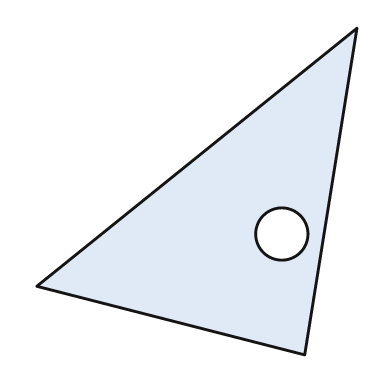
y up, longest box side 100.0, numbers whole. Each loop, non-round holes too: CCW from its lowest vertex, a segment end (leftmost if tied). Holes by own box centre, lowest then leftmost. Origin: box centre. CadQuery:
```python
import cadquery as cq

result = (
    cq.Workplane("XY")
    .moveTo(33.0, -50.0)
    .lineTo(49.0, 50.0)
    .lineTo(-49.0, -29.0)
    .close()
    .moveTo(26.0, -13.0)
    .circle(8.0)
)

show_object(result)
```